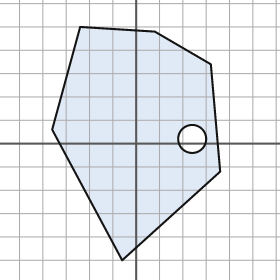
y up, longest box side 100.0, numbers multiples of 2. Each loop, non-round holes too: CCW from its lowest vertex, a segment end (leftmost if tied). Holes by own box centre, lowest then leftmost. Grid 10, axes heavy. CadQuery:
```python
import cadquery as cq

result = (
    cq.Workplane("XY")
    .moveTo(-6.0, -50.0)
    .lineTo(36.0, -12.0)
    .lineTo(32.0, 34.0)
    .lineTo(8.0, 48.0)
    .lineTo(-24.0, 50.0)
    .lineTo(-36.0, 6.0)
    .close()
    .moveTo(24.0, 2.0)
    .circle(6.0)
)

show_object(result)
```